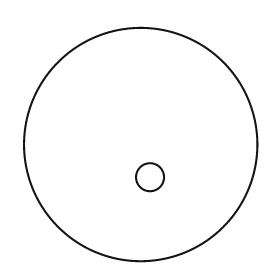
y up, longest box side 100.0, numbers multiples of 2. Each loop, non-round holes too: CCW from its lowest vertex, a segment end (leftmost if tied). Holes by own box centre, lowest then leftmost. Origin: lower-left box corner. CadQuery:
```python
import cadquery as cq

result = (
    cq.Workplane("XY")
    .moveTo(50.0, 50.0)
    .circle(50.0)
    .moveTo(54.0, 36.0)
    .circle(6.0)
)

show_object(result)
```